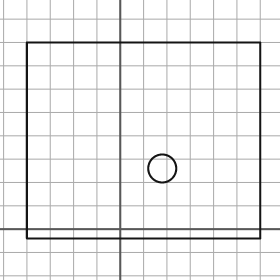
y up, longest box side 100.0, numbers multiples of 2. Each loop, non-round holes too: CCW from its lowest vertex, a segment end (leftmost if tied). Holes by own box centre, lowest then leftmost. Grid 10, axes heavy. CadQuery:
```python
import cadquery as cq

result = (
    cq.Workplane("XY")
    .moveTo(-40.0, -4.0)
    .lineTo(60.0, -4.0)
    .lineTo(60.0, 80.0)
    .lineTo(-40.0, 80.0)
    .close()
    .moveTo(18.0, 26.0)
    .circle(6.0)
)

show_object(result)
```